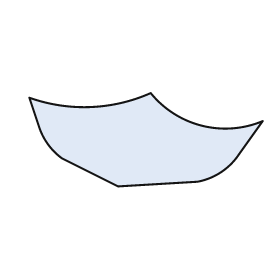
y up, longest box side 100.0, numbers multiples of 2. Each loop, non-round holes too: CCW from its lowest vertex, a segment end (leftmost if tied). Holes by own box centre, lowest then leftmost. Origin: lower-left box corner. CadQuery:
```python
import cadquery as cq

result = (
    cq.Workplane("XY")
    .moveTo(38.0, 0.0)
    .lineTo(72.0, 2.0)
    .threePointArc((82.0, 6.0), (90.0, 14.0))
    .lineTo(100.0, 28.0)
    .threePointArc((74.0, 26.0), (52.0, 40.0))
    .threePointArc((26.0, 34.0), (0.0, 38.0))
    .lineTo(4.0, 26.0)
    .threePointArc((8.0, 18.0), (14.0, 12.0))
    .close()
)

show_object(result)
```